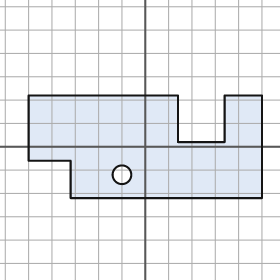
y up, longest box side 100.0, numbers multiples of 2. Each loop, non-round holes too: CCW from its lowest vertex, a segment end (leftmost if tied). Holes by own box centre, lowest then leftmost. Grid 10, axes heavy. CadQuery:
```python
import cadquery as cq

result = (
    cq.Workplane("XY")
    .moveTo(-32.0, -22.0)
    .lineTo(50.0, -22.0)
    .lineTo(50.0, 22.0)
    .lineTo(34.0, 22.0)
    .lineTo(34.0, 2.0)
    .lineTo(14.0, 2.0)
    .lineTo(14.0, 22.0)
    .lineTo(-50.0, 22.0)
    .lineTo(-50.0, -6.0)
    .lineTo(-32.0, -6.0)
    .close()
    .moveTo(-10.0, -12.0)
    .circle(4.0)
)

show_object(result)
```